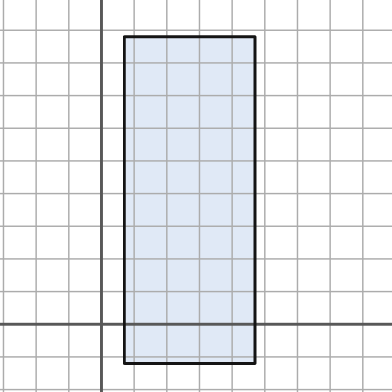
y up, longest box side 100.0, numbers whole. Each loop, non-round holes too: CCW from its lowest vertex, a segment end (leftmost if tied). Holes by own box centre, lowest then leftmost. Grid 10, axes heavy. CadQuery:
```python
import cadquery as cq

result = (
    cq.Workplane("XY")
    .moveTo(7.0, -12.0)
    .lineTo(47.0, -12.0)
    .lineTo(47.0, 88.0)
    .lineTo(7.0, 88.0)
    .close()
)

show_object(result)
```